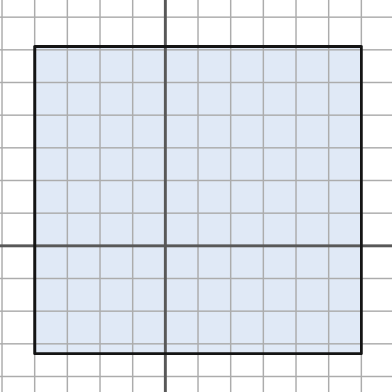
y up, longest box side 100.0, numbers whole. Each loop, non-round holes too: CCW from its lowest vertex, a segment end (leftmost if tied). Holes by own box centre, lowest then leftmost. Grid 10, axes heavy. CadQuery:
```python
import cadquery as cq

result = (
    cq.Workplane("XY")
    .moveTo(-40.0, -33.0)
    .lineTo(60.0, -33.0)
    .lineTo(60.0, 61.0)
    .lineTo(-40.0, 61.0)
    .close()
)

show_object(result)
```